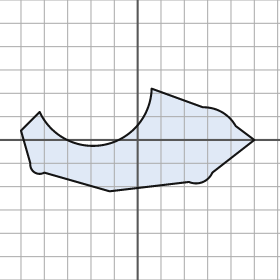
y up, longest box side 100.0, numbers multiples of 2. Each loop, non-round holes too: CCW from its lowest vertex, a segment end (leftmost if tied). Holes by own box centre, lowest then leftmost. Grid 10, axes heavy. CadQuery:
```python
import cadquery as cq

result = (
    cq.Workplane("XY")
    .moveTo(-12.0, -22.0)
    .lineTo(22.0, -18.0)
    .threePointArc((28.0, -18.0), (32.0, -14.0))
    .lineTo(50.0, 0.0)
    .lineTo(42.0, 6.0)
    .threePointArc((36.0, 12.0), (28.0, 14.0))
    .lineTo(6.0, 22.0)
    .threePointArc((-14.0, -2.0), (-42.0, 12.0))
    .lineTo(-50.0, 4.0)
    .lineTo(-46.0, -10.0)
    .threePointArc((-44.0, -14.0), (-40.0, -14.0))
    .close()
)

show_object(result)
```